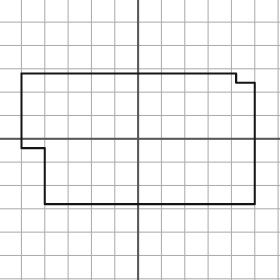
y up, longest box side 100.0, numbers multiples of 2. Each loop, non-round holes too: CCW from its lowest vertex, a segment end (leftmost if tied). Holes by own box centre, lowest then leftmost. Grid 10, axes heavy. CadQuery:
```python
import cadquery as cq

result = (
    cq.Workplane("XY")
    .moveTo(-40.0, -28.0)
    .lineTo(50.0, -28.0)
    .lineTo(50.0, 24.0)
    .lineTo(42.0, 24.0)
    .lineTo(42.0, 28.0)
    .lineTo(-50.0, 28.0)
    .lineTo(-50.0, -4.0)
    .lineTo(-40.0, -4.0)
    .close()
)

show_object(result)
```